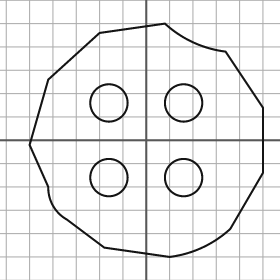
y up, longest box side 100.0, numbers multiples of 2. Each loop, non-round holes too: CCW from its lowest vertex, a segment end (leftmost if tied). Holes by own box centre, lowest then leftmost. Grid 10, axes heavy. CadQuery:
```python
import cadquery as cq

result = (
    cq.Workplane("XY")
    .moveTo(10.0, -50.0)
    .threePointArc((24.0, -46.0), (36.0, -38.0))
    .lineTo(50.0, -14.0)
    .lineTo(50.0, 14.0)
    .lineTo(34.0, 38.0)
    .threePointArc((20.0, 42.0), (8.0, 50.0))
    .lineTo(-20.0, 46.0)
    .lineTo(-42.0, 26.0)
    .lineTo(-50.0, -2.0)
    .lineTo(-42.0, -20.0)
    .threePointArc((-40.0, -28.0), (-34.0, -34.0))
    .lineTo(-18.0, -46.0)
    .close()
    .moveTo(-16.0, -16.0)
    .circle(8.0)
    .moveTo(16.0, -16.0)
    .circle(8.0)
    .moveTo(-16.0, 16.0)
    .circle(8.0)
    .moveTo(16.0, 16.0)
    .circle(8.0)
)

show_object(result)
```